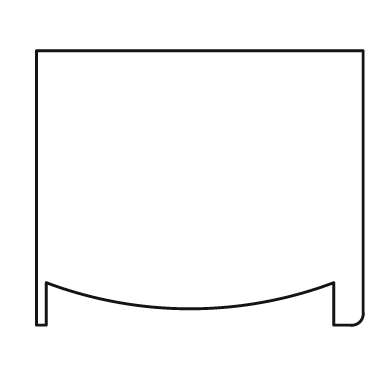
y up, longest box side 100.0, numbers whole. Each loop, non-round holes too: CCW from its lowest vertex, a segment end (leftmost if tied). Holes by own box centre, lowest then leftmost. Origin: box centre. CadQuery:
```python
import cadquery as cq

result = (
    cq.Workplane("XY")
    .moveTo(-50.0, -42.0)
    .lineTo(-47.0, -42.0)
    .lineTo(-47.0, -29.0)
    .threePointArc((-3.0, -37.0), (41.0, -29.0))
    .lineTo(41.0, -42.0)
    .lineTo(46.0, -42.0)
    .threePointArc((49.0, -41.0), (50.0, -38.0))
    .lineTo(50.0, 42.0)
    .lineTo(-50.0, 42.0)
    .close()
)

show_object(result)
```